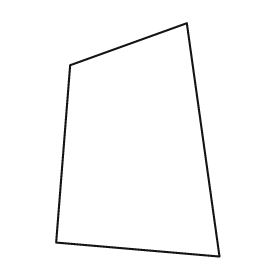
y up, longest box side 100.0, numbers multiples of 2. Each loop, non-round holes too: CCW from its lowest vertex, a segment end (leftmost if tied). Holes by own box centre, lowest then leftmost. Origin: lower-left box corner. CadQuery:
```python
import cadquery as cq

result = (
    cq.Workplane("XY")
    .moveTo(70.0, 0.0)
    .lineTo(56.0, 100.0)
    .lineTo(6.0, 82.0)
    .lineTo(0.0, 6.0)
    .close()
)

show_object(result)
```